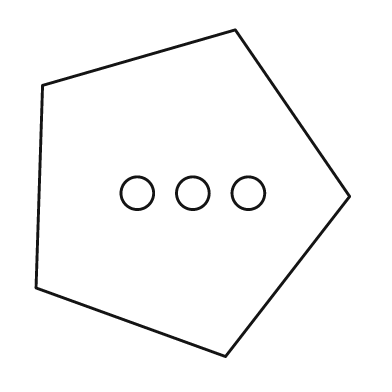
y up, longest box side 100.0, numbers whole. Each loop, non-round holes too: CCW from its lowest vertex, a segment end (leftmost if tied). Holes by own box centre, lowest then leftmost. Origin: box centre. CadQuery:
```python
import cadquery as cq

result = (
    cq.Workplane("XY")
    .moveTo(10.0, -50.0)
    .lineTo(48.0, -1.0)
    .lineTo(13.0, 50.0)
    .lineTo(-46.0, 33.0)
    .lineTo(-48.0, -29.0)
    .close()
    .moveTo(-17.0, 0.0)
    .circle(5.0)
    .moveTo(0.0, 0.0)
    .circle(5.0)
    .moveTo(17.0, 0.0)
    .circle(5.0)
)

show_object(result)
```